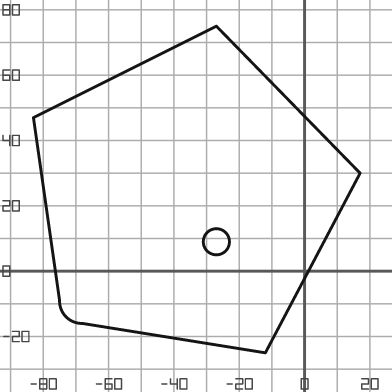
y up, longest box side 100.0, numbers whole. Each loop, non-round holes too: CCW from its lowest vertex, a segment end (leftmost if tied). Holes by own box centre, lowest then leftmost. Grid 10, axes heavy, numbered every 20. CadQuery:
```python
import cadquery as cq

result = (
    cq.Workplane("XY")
    .moveTo(-12.0, -25.0)
    .lineTo(17.0, 30.0)
    .lineTo(-27.0, 75.0)
    .lineTo(-83.0, 47.0)
    .lineTo(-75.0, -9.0)
    .threePointArc((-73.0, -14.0), (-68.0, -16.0))
    .close()
    .moveTo(-27.0, 9.0)
    .circle(4.0)
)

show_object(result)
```